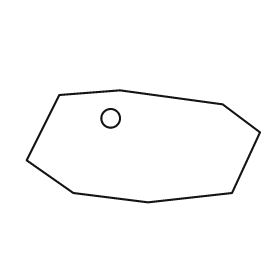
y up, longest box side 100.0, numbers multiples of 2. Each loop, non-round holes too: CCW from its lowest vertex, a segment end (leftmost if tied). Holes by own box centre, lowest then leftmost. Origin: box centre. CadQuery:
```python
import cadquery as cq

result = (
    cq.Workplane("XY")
    .moveTo(2.0, -24.0)
    .lineTo(38.0, -20.0)
    .lineTo(50.0, 6.0)
    .lineTo(34.0, 18.0)
    .lineTo(-10.0, 24.0)
    .lineTo(-36.0, 22.0)
    .lineTo(-50.0, -6.0)
    .lineTo(-30.0, -20.0)
    .close()
    .moveTo(-14.0, 12.0)
    .circle(4.0)
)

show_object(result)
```